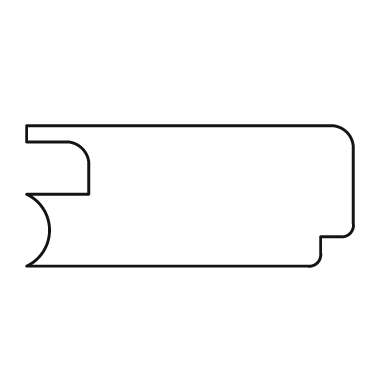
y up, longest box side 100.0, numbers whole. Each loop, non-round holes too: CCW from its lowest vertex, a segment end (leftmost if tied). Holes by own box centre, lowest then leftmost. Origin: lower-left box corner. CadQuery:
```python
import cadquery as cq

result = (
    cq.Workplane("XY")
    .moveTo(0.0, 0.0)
    .lineTo(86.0, 0.0)
    .threePointArc((89.0, 1.0), (90.0, 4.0))
    .lineTo(90.0, 9.0)
    .lineTo(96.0, 9.0)
    .threePointArc((99.0, 10.0), (100.0, 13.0))
    .lineTo(100.0, 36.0)
    .threePointArc((98.0, 41.0), (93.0, 43.0))
    .lineTo(0.0, 43.0)
    .lineTo(0.0, 38.0)
    .lineTo(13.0, 38.0)
    .threePointArc((17.0, 36.0), (19.0, 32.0))
    .lineTo(19.0, 22.0)
    .lineTo(0.0, 22.0)
    .threePointArc((7.0, 11.0), (0.0, 0.0))
    .close()
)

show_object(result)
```